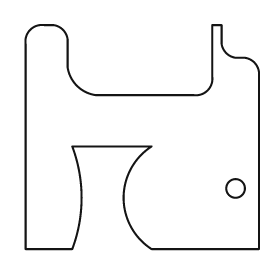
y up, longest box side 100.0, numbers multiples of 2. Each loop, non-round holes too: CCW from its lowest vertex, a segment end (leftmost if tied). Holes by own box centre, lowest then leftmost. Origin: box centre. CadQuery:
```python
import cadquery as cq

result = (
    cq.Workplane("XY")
    .moveTo(-50.0, -48.0)
    .lineTo(-30.0, -48.0)
    .threePointArc((-26.0, -26.0), (-30.0, -4.0))
    .lineTo(4.0, -4.0)
    .threePointArc((-8.0, -26.0), (4.0, -48.0))
    .lineTo(50.0, -48.0)
    .lineTo(50.0, 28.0)
    .threePointArc((48.0, 32.0), (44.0, 34.0))
    .lineTo(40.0, 34.0)
    .threePointArc((36.0, 36.0), (34.0, 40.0))
    .lineTo(34.0, 48.0)
    .lineTo(30.0, 48.0)
    .lineTo(30.0, 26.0)
    .threePointArc((28.0, 20.0), (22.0, 18.0))
    .lineTo(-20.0, 18.0)
    .threePointArc((-28.0, 22.0), (-32.0, 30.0))
    .lineTo(-32.0, 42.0)
    .threePointArc((-34.0, 46.0), (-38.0, 48.0))
    .lineTo(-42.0, 48.0)
    .threePointArc((-48.0, 46.0), (-50.0, 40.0))
    .close()
    .moveTo(40.0, -22.0)
    .circle(4.0)
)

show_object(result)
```